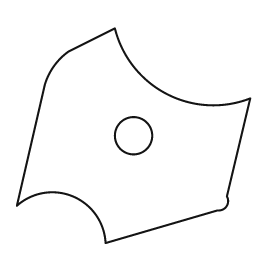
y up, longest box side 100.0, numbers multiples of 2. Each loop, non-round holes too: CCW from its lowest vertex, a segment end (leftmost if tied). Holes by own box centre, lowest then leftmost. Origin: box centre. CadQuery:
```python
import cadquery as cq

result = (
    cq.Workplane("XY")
    .moveTo(-12.0, -46.0)
    .lineTo(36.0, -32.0)
    .threePointArc((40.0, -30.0), (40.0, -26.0))
    .lineTo(50.0, 16.0)
    .threePointArc((14.0, 18.0), (-8.0, 46.0))
    .lineTo(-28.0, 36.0)
    .threePointArc((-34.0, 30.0), (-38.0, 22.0))
    .lineTo(-50.0, -30.0)
    .threePointArc((-26.0, -26.0), (-12.0, -46.0))
    .close()
    .moveTo(0.0, 0.0)
    .circle(8.0)
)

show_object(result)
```